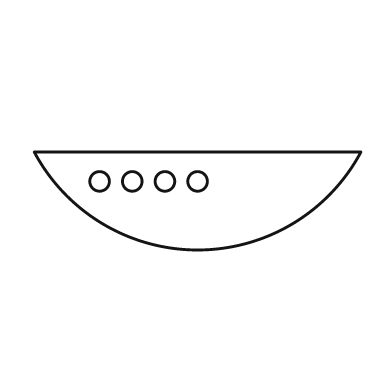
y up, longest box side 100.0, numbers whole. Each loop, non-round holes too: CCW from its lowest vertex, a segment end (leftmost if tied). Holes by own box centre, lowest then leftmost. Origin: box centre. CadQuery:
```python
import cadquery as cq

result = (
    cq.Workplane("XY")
    .moveTo(-50.0, 15.0)
    .threePointArc((0.0, -15.0), (50.0, 15.0))
    .close()
    .moveTo(-30.0, 6.0)
    .circle(3.0)
    .moveTo(-20.0, 6.0)
    .circle(3.0)
    .moveTo(-10.0, 6.0)
    .circle(3.0)
    .moveTo(0.0, 6.0)
    .circle(3.0)
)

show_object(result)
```